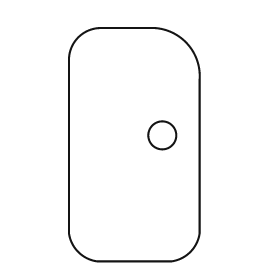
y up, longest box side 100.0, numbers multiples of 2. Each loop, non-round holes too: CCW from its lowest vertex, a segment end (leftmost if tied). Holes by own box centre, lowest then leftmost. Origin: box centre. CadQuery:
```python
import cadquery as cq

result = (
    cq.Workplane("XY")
    .moveTo(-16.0, -50.0)
    .lineTo(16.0, -50.0)
    .threePointArc((24.0, -46.0), (28.0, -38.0))
    .lineTo(28.0, 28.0)
    .threePointArc((22.0, 44.0), (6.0, 50.0))
    .lineTo(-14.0, 50.0)
    .threePointArc((-24.0, 46.0), (-28.0, 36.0))
    .lineTo(-28.0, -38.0)
    .threePointArc((-24.0, -46.0), (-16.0, -50.0))
    .close()
    .moveTo(12.0, 4.0)
    .circle(6.0)
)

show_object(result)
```